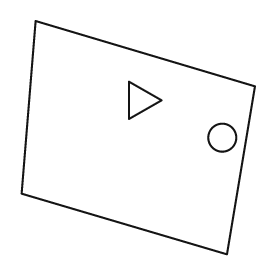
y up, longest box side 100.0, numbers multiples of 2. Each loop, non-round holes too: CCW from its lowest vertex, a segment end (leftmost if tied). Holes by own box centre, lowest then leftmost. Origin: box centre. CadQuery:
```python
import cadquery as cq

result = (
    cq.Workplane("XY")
    .moveTo(38.0, -50.0)
    .lineTo(50.0, 22.0)
    .lineTo(-44.0, 50.0)
    .lineTo(-50.0, -24.0)
    .close()
    .moveTo(36.0, 0.0)
    .circle(6.0)
    .moveTo(-4.0, 8.0)
    .lineTo(10.0, 16.0)
    .lineTo(-4.0, 24.0)
    .close()
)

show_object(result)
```